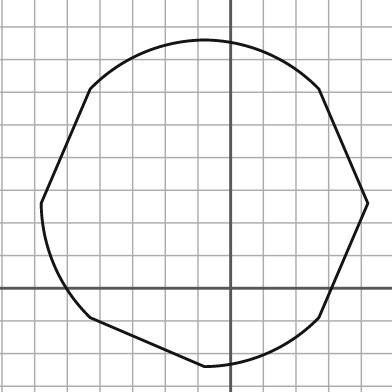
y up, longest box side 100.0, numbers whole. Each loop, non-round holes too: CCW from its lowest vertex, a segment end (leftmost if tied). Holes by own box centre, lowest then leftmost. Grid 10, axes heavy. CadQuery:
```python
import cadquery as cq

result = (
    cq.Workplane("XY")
    .moveTo(-8.0, -24.0)
    .threePointArc((11.0, -20.0), (27.0, -9.0))
    .lineTo(42.0, 26.0)
    .lineTo(27.0, 61.0)
    .threePointArc((11.0, 72.0), (-8.0, 76.0))
    .threePointArc((-27.0, 72.0), (-43.0, 61.0))
    .lineTo(-58.0, 26.0)
    .threePointArc((-54.0, 7.0), (-43.0, -9.0))
    .close()
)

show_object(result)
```